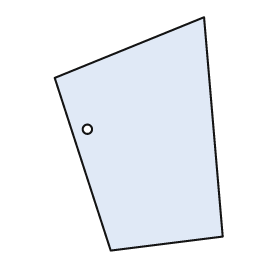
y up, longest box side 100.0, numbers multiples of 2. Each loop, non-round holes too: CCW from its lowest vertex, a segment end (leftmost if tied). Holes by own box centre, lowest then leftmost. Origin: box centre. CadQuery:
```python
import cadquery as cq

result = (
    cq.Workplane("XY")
    .moveTo(-12.0, -50.0)
    .lineTo(36.0, -44.0)
    .lineTo(28.0, 50.0)
    .lineTo(-36.0, 24.0)
    .close()
    .moveTo(-22.0, 2.0)
    .circle(2.0)
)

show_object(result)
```